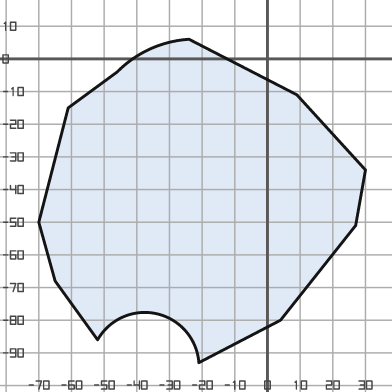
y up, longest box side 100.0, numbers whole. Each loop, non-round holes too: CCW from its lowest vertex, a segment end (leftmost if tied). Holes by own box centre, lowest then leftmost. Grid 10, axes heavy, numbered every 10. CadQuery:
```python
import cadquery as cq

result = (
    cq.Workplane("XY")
    .moveTo(-21.0, -93.0)
    .lineTo(4.0, -80.0)
    .lineTo(27.0, -51.0)
    .lineTo(30.0, -34.0)
    .lineTo(9.0, -11.0)
    .lineTo(-24.0, 6.0)
    .threePointArc((-36.0, 3.0), (-46.0, -4.0))
    .lineTo(-61.0, -15.0)
    .lineTo(-70.0, -50.0)
    .lineTo(-65.0, -68.0)
    .lineTo(-52.0, -86.0)
    .threePointArc((-34.0, -78.0), (-21.0, -93.0))
    .close()
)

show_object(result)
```